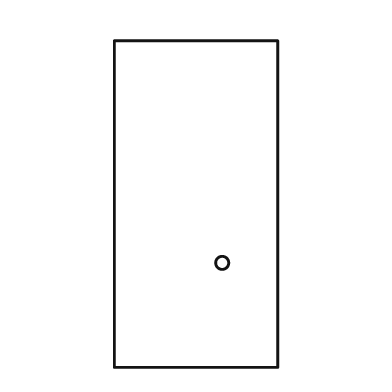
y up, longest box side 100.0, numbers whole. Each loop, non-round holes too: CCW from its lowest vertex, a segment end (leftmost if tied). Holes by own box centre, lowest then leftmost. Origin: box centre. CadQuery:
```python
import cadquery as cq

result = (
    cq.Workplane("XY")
    .moveTo(-25.0, -50.0)
    .lineTo(25.0, -50.0)
    .lineTo(25.0, 50.0)
    .lineTo(-25.0, 50.0)
    .close()
    .moveTo(8.0, -18.0)
    .circle(2.0)
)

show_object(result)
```